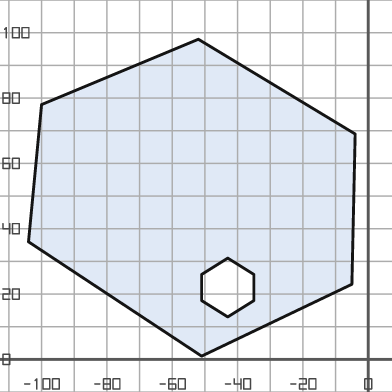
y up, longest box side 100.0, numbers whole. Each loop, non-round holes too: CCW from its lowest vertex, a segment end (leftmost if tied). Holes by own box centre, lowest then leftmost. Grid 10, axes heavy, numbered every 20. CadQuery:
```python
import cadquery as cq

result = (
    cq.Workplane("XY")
    .moveTo(-51.0, 1.0)
    .lineTo(-5.0, 23.0)
    .lineTo(-4.0, 69.0)
    .lineTo(-52.0, 98.0)
    .lineTo(-100.0, 78.0)
    .lineTo(-104.0, 36.0)
    .close()
    .moveTo(-43.0, 13.0)
    .lineTo(-35.0, 18.0)
    .lineTo(-35.0, 26.0)
    .lineTo(-43.0, 31.0)
    .lineTo(-51.0, 26.0)
    .lineTo(-51.0, 18.0)
    .close()
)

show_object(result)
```